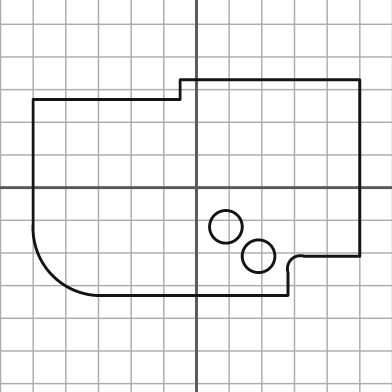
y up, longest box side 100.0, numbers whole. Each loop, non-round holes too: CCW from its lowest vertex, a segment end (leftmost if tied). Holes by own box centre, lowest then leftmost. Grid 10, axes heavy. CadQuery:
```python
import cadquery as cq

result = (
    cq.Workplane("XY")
    .moveTo(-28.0, -33.0)
    .lineTo(28.0, -33.0)
    .lineTo(28.0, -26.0)
    .threePointArc((29.0, -22.0), (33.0, -21.0))
    .lineTo(50.0, -21.0)
    .lineTo(50.0, 33.0)
    .lineTo(-5.0, 33.0)
    .lineTo(-5.0, 27.0)
    .lineTo(-50.0, 27.0)
    .lineTo(-50.0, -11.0)
    .threePointArc((-44.0, -27.0), (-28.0, -33.0))
    .close()
    .moveTo(19.0, -21.0)
    .circle(5.0)
    .moveTo(9.0, -12.0)
    .circle(5.0)
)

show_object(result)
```